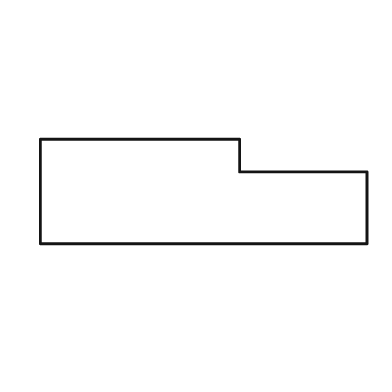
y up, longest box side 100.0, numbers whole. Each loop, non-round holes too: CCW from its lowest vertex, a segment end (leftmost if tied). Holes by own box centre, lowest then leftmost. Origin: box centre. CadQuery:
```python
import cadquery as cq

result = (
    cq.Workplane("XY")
    .moveTo(-50.0, -16.0)
    .lineTo(50.0, -16.0)
    .lineTo(50.0, 6.0)
    .lineTo(11.0, 6.0)
    .lineTo(11.0, 16.0)
    .lineTo(-50.0, 16.0)
    .close()
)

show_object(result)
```